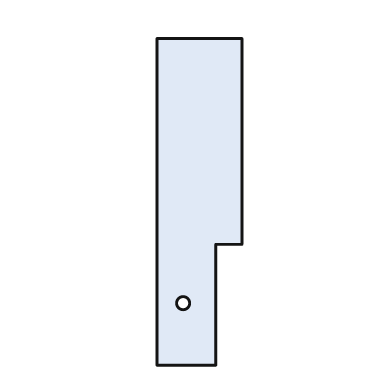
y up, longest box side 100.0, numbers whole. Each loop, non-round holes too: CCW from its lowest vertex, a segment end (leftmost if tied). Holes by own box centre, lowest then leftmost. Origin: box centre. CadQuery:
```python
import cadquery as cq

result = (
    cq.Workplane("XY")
    .moveTo(-13.0, -50.0)
    .lineTo(5.0, -50.0)
    .lineTo(5.0, -13.0)
    .lineTo(13.0, -13.0)
    .lineTo(13.0, 50.0)
    .lineTo(-13.0, 50.0)
    .close()
    .moveTo(-5.0, -31.0)
    .circle(2.0)
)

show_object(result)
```